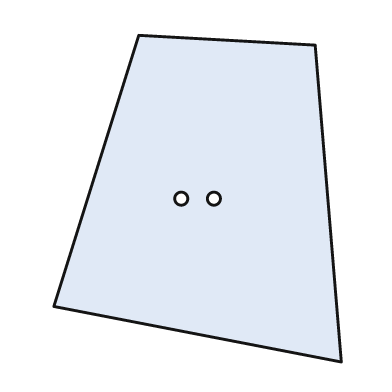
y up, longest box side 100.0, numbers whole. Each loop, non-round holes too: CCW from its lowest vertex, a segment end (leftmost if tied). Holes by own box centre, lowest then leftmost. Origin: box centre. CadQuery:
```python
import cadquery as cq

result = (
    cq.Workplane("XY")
    .moveTo(44.0, -50.0)
    .lineTo(36.0, 47.0)
    .lineTo(-18.0, 50.0)
    .lineTo(-44.0, -33.0)
    .close()
    .moveTo(-5.0, 0.0)
    .circle(2.0)
    .moveTo(5.0, 0.0)
    .circle(2.0)
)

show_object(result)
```